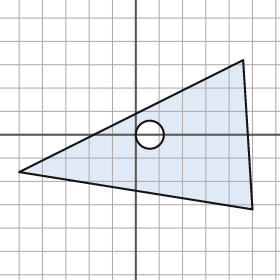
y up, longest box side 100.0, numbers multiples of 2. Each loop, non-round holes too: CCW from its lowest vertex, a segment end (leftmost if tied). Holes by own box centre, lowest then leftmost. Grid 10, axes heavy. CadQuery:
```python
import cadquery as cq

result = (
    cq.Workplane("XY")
    .moveTo(50.0, -32.0)
    .lineTo(46.0, 32.0)
    .lineTo(-50.0, -16.0)
    .close()
    .moveTo(6.0, 0.0)
    .circle(6.0)
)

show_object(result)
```